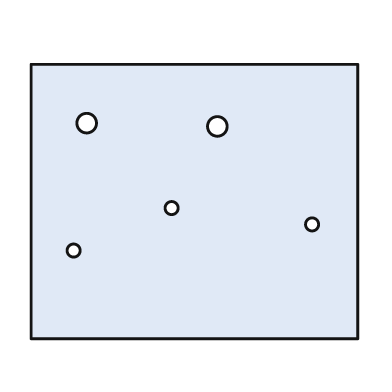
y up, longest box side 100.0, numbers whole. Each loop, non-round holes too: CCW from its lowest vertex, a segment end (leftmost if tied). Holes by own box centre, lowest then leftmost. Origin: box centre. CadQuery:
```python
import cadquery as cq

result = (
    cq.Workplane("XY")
    .moveTo(-50.0, -42.0)
    .lineTo(50.0, -42.0)
    .lineTo(50.0, 42.0)
    .lineTo(-50.0, 42.0)
    .close()
    .moveTo(-37.0, -15.0)
    .circle(2.0)
    .moveTo(36.0, -7.0)
    .circle(2.0)
    .moveTo(-7.0, -2.0)
    .circle(2.0)
    .moveTo(7.0, 23.0)
    .circle(3.0)
    .moveTo(-33.0, 24.0)
    .circle(3.0)
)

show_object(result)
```